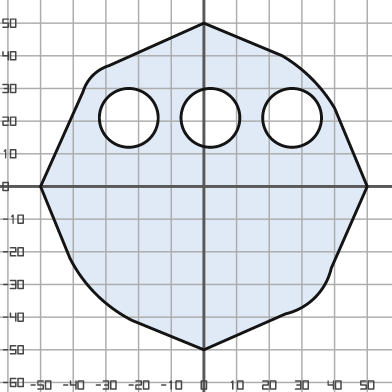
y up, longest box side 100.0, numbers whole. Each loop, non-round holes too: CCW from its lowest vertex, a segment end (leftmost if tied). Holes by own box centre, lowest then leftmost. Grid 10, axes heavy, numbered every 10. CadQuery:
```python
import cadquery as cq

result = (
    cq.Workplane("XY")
    .moveTo(0.0, -50.0)
    .lineTo(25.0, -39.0)
    .threePointArc((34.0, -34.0), (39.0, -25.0))
    .lineTo(50.0, 0.0)
    .lineTo(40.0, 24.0)
    .threePointArc((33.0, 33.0), (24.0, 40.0))
    .lineTo(0.0, 50.0)
    .lineTo(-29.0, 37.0)
    .threePointArc((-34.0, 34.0), (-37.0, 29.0))
    .lineTo(-50.0, 0.0)
    .lineTo(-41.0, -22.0)
    .threePointArc((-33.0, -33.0), (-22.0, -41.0))
    .close()
    .moveTo(-23.0, 21.0)
    .circle(9.0)
    .moveTo(2.0, 21.0)
    .circle(9.0)
    .moveTo(27.0, 21.0)
    .circle(9.0)
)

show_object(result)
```